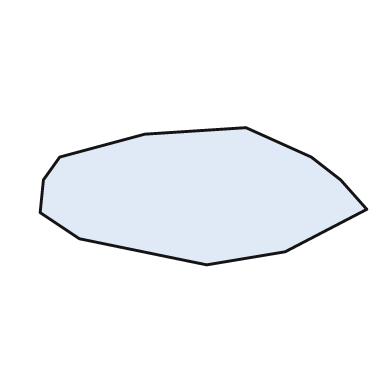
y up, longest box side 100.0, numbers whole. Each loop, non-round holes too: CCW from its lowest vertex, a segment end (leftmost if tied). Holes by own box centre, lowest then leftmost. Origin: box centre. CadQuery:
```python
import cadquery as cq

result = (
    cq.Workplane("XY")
    .moveTo(1.0, -21.0)
    .lineTo(25.0, -17.0)
    .lineTo(50.0, -4.0)
    .lineTo(42.0, 5.0)
    .lineTo(33.0, 12.0)
    .lineTo(13.0, 21.0)
    .lineTo(-18.0, 19.0)
    .lineTo(-44.0, 12.0)
    .lineTo(-49.0, 5.0)
    .lineTo(-50.0, -5.0)
    .lineTo(-38.0, -13.0)
    .close()
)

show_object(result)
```